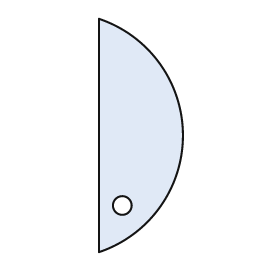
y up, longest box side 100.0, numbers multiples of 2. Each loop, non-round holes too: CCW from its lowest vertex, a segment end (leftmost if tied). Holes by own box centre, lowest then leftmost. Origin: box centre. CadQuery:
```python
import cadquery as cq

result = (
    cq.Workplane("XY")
    .moveTo(-18.0, -50.0)
    .threePointArc((18.0, 0.0), (-18.0, 50.0))
    .close()
    .moveTo(-8.0, -30.0)
    .circle(4.0)
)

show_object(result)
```